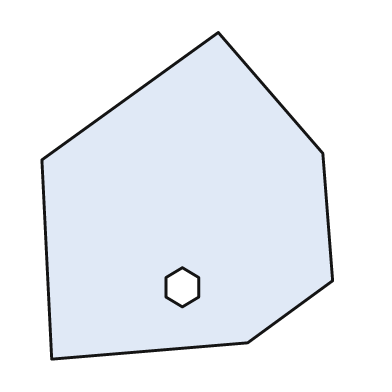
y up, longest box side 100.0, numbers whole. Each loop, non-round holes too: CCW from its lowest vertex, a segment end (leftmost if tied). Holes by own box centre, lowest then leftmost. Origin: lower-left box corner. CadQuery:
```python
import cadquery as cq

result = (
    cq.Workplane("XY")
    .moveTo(3.0, 0.0)
    .lineTo(63.0, 5.0)
    .lineTo(89.0, 24.0)
    .lineTo(86.0, 63.0)
    .lineTo(54.0, 100.0)
    .lineTo(0.0, 61.0)
    .close()
    .moveTo(43.0, 16.0)
    .lineTo(48.0, 19.0)
    .lineTo(48.0, 25.0)
    .lineTo(43.0, 28.0)
    .lineTo(38.0, 25.0)
    .lineTo(38.0, 19.0)
    .close()
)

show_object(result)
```